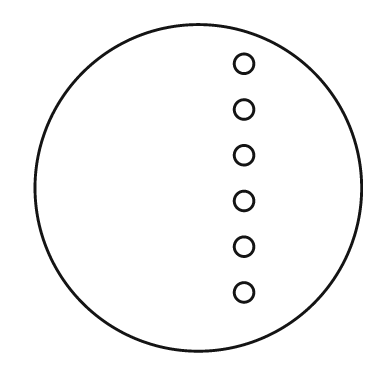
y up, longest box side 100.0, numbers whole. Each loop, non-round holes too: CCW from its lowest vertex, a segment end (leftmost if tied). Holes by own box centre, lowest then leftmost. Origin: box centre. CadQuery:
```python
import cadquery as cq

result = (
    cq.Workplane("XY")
    .moveTo(0.0, 0.0)
    .circle(50.0)
    .moveTo(14.0, -32.0)
    .circle(3.0)
    .moveTo(14.0, -18.0)
    .circle(3.0)
    .moveTo(14.0, -4.0)
    .circle(3.0)
    .moveTo(14.0, 10.0)
    .circle(3.0)
    .moveTo(14.0, 24.0)
    .circle(3.0)
    .moveTo(14.0, 38.0)
    .circle(3.0)
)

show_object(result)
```